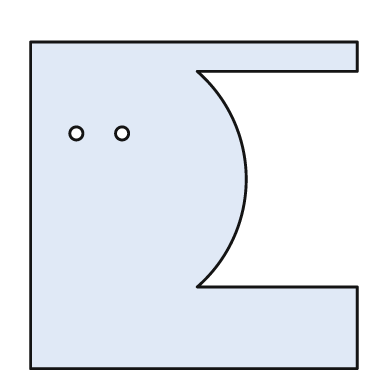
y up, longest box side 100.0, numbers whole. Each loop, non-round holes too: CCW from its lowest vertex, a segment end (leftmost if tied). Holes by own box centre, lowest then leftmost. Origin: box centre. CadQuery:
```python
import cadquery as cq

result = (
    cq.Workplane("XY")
    .moveTo(-50.0, -50.0)
    .lineTo(50.0, -50.0)
    .lineTo(50.0, -25.0)
    .lineTo(1.0, -25.0)
    .threePointArc((16.0, 8.0), (1.0, 41.0))
    .lineTo(50.0, 41.0)
    .lineTo(50.0, 50.0)
    .lineTo(-50.0, 50.0)
    .close()
    .moveTo(-36.0, 22.0)
    .circle(2.0)
    .moveTo(-22.0, 22.0)
    .circle(2.0)
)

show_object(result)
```